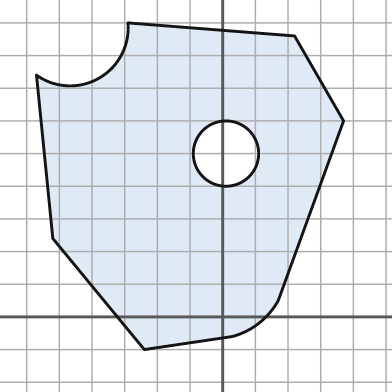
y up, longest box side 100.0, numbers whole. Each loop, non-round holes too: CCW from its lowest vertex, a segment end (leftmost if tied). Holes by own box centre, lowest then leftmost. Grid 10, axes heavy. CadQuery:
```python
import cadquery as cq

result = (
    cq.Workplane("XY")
    .moveTo(-24.0, -10.0)
    .lineTo(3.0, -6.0)
    .threePointArc((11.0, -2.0), (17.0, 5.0))
    .lineTo(37.0, 60.0)
    .lineTo(22.0, 86.0)
    .lineTo(-29.0, 90.0)
    .threePointArc((-38.0, 73.0), (-57.0, 74.0))
    .lineTo(-52.0, 24.0)
    .close()
    .moveTo(1.0, 50.0)
    .circle(10.0)
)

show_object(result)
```